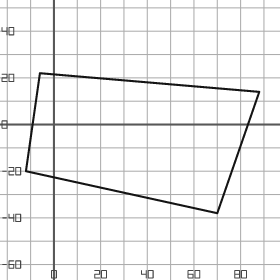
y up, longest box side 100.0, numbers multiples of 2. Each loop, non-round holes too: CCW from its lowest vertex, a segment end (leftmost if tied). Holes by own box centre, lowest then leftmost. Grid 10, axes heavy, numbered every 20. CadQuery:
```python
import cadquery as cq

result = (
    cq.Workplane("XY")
    .moveTo(70.0, -38.0)
    .lineTo(88.0, 14.0)
    .lineTo(-6.0, 22.0)
    .lineTo(-12.0, -20.0)
    .close()
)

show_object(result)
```